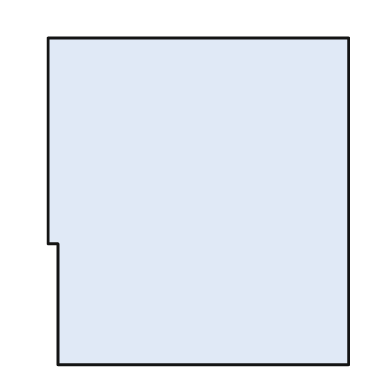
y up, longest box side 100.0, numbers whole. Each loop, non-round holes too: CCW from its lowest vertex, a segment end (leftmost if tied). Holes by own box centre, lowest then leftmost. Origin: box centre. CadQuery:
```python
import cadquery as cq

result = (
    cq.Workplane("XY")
    .moveTo(-43.0, -50.0)
    .lineTo(46.0, -50.0)
    .lineTo(46.0, 50.0)
    .lineTo(-46.0, 50.0)
    .lineTo(-46.0, -13.0)
    .lineTo(-43.0, -13.0)
    .close()
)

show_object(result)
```